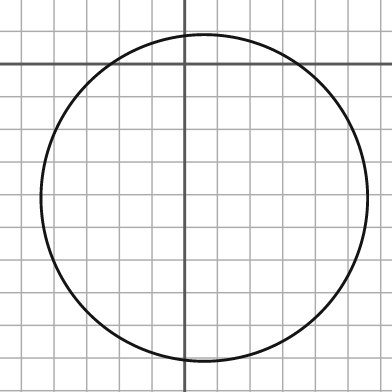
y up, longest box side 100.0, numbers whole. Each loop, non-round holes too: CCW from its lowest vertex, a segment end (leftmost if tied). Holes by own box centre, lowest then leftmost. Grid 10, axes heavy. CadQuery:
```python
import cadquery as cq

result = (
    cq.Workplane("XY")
    .moveTo(6.0, -41.0)
    .circle(50.0)
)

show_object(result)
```